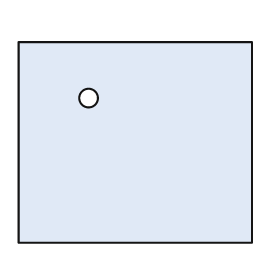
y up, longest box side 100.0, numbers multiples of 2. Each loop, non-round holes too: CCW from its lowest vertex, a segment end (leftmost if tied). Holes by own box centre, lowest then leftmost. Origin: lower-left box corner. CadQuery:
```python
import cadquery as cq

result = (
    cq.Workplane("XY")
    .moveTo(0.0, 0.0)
    .lineTo(100.0, 0.0)
    .lineTo(100.0, 86.0)
    .lineTo(0.0, 86.0)
    .close()
    .moveTo(30.0, 62.0)
    .circle(4.0)
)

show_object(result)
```